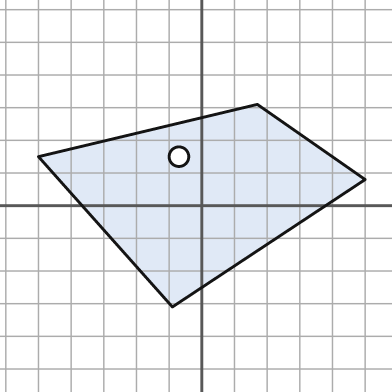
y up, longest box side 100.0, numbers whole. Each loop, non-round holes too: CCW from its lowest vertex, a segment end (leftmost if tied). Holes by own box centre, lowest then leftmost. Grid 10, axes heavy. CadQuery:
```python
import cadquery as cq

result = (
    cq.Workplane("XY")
    .moveTo(-9.0, -31.0)
    .lineTo(50.0, 8.0)
    .lineTo(17.0, 31.0)
    .lineTo(-50.0, 15.0)
    .close()
    .moveTo(-7.0, 15.0)
    .circle(3.0)
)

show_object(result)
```